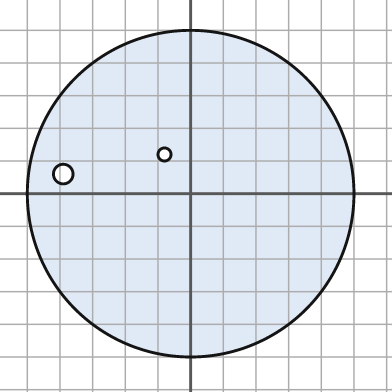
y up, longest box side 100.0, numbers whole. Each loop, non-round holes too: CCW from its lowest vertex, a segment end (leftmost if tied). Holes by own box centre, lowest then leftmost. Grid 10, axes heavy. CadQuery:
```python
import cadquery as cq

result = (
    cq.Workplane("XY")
    .moveTo(0.0, 0.0)
    .circle(50.0)
    .moveTo(-39.0, 6.0)
    .circle(3.0)
    .moveTo(-8.0, 12.0)
    .circle(2.0)
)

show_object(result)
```